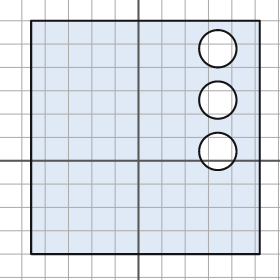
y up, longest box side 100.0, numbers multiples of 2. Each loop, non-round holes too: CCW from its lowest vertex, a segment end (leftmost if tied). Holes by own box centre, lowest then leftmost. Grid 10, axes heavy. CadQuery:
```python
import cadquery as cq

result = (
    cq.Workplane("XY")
    .moveTo(-46.0, -40.0)
    .lineTo(52.0, -40.0)
    .lineTo(52.0, 60.0)
    .lineTo(-46.0, 60.0)
    .close()
    .moveTo(34.0, 4.0)
    .circle(8.0)
    .moveTo(34.0, 26.0)
    .circle(8.0)
    .moveTo(34.0, 48.0)
    .circle(8.0)
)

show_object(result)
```